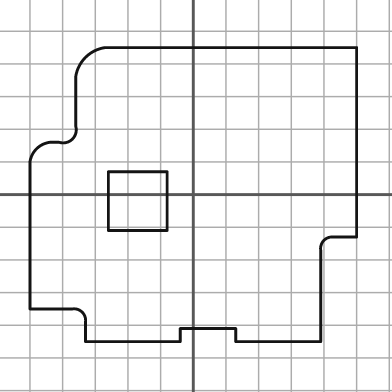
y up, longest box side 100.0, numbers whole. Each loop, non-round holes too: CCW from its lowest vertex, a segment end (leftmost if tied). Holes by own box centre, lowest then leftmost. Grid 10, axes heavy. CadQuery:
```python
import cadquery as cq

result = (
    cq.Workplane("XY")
    .moveTo(-33.0, -45.0)
    .lineTo(-4.0, -45.0)
    .lineTo(-4.0, -41.0)
    .lineTo(13.0, -41.0)
    .lineTo(13.0, -45.0)
    .lineTo(39.0, -45.0)
    .lineTo(39.0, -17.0)
    .threePointArc((40.0, -14.0), (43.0, -13.0))
    .lineTo(50.0, -13.0)
    .lineTo(50.0, 45.0)
    .lineTo(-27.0, 45.0)
    .threePointArc((-33.0, 42.0), (-36.0, 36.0))
    .lineTo(-36.0, 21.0)
    .threePointArc((-37.0, 17.0), (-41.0, 16.0))
    .lineTo(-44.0, 16.0)
    .threePointArc((-48.0, 14.0), (-50.0, 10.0))
    .lineTo(-50.0, -35.0)
    .lineTo(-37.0, -35.0)
    .threePointArc((-34.0, -36.0), (-33.0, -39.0))
    .close()
    .moveTo(-26.0, -11.0)
    .lineTo(-8.0, -11.0)
    .lineTo(-8.0, 7.0)
    .lineTo(-26.0, 7.0)
    .close()
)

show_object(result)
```